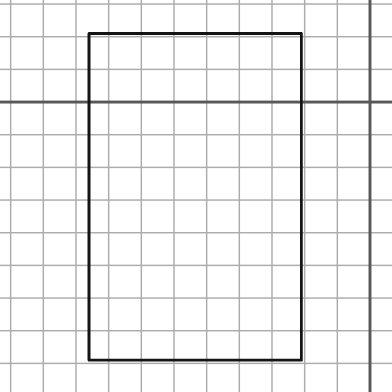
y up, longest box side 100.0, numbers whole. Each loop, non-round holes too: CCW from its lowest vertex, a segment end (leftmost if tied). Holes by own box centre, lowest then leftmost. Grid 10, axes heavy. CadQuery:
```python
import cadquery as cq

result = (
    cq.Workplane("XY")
    .moveTo(-86.0, -79.0)
    .lineTo(-21.0, -79.0)
    .lineTo(-21.0, 21.0)
    .lineTo(-86.0, 21.0)
    .close()
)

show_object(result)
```